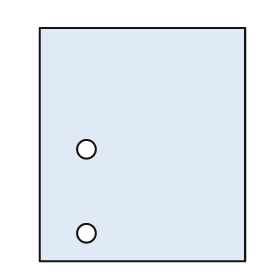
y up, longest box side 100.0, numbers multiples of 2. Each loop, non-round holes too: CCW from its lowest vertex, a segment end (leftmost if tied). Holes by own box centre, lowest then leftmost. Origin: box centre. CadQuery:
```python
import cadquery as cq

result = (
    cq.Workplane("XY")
    .moveTo(-44.0, -50.0)
    .lineTo(44.0, -50.0)
    .lineTo(44.0, 50.0)
    .lineTo(-44.0, 50.0)
    .close()
    .moveTo(-24.0, -38.0)
    .circle(4.0)
    .moveTo(-24.0, -2.0)
    .circle(4.0)
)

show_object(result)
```